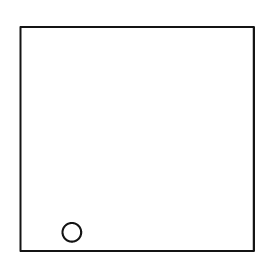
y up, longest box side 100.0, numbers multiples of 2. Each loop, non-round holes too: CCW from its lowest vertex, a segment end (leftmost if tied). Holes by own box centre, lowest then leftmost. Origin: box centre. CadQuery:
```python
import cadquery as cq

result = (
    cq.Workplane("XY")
    .moveTo(-50.0, -48.0)
    .lineTo(50.0, -48.0)
    .lineTo(50.0, 48.0)
    .lineTo(-50.0, 48.0)
    .close()
    .moveTo(-28.0, -40.0)
    .circle(4.0)
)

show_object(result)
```